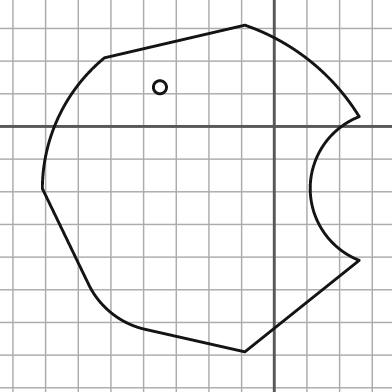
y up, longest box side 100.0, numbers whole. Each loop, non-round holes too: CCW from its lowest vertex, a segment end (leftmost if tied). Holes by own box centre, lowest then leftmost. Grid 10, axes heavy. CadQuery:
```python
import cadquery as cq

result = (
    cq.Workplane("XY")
    .moveTo(-9.0, -69.0)
    .lineTo(26.0, -41.0)
    .threePointArc((11.0, -19.0), (26.0, 3.0))
    .threePointArc((11.0, 20.0), (-9.0, 31.0))
    .lineTo(-52.0, 21.0)
    .threePointArc((-66.0, 3.0), (-71.0, -19.0))
    .lineTo(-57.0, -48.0)
    .threePointArc((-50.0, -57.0), (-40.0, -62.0))
    .close()
    .moveTo(-35.0, 12.0)
    .circle(2.0)
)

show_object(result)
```